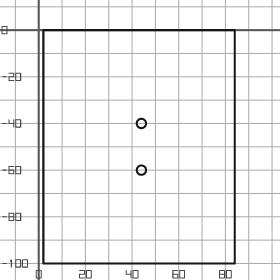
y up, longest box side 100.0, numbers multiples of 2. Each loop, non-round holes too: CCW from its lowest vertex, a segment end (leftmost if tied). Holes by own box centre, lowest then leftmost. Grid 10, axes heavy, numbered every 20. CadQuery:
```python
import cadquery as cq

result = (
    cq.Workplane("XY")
    .moveTo(2.0, -100.0)
    .lineTo(84.0, -100.0)
    .lineTo(84.0, 0.0)
    .lineTo(2.0, 0.0)
    .close()
    .moveTo(44.0, -60.0)
    .circle(2.0)
    .moveTo(44.0, -40.0)
    .circle(2.0)
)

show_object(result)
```